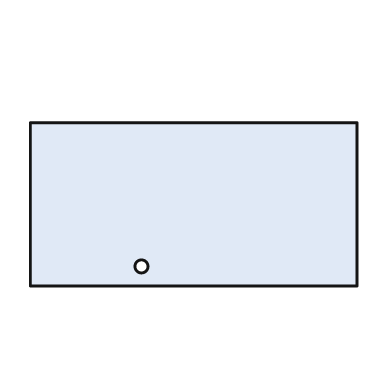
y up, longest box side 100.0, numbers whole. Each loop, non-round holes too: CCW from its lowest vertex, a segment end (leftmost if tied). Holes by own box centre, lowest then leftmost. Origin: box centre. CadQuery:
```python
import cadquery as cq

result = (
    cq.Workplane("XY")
    .moveTo(-50.0, -25.0)
    .lineTo(50.0, -25.0)
    .lineTo(50.0, 25.0)
    .lineTo(-50.0, 25.0)
    .close()
    .moveTo(-16.0, -19.0)
    .circle(2.0)
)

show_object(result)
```